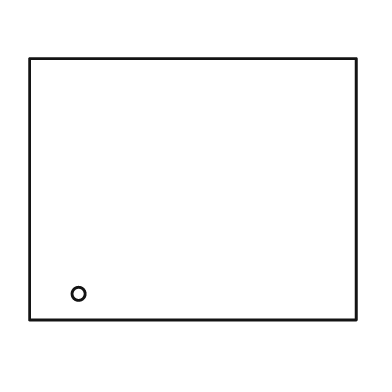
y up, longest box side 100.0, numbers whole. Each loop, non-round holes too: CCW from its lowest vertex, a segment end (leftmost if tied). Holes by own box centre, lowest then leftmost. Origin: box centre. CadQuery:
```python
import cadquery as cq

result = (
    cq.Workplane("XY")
    .moveTo(-50.0, -40.0)
    .lineTo(50.0, -40.0)
    .lineTo(50.0, 40.0)
    .lineTo(-50.0, 40.0)
    .close()
    .moveTo(-35.0, -32.0)
    .circle(2.0)
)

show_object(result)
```